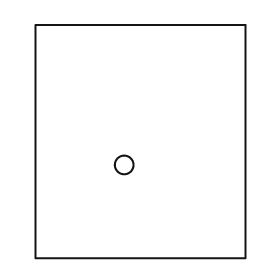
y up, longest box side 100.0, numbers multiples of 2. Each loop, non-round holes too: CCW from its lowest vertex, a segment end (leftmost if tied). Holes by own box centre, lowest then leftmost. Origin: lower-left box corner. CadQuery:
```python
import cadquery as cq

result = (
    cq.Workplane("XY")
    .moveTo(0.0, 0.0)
    .lineTo(90.0, 0.0)
    .lineTo(90.0, 100.0)
    .lineTo(0.0, 100.0)
    .close()
    .moveTo(38.0, 40.0)
    .circle(4.0)
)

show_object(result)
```